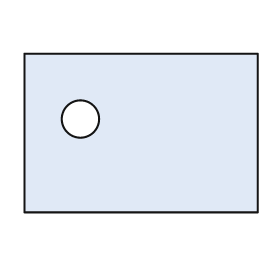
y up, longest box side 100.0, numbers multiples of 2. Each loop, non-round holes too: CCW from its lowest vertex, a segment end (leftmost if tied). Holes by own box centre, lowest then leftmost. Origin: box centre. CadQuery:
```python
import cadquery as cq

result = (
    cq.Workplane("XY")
    .moveTo(-50.0, -34.0)
    .lineTo(50.0, -34.0)
    .lineTo(50.0, 34.0)
    .lineTo(-50.0, 34.0)
    .close()
    .moveTo(-26.0, 6.0)
    .circle(8.0)
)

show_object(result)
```